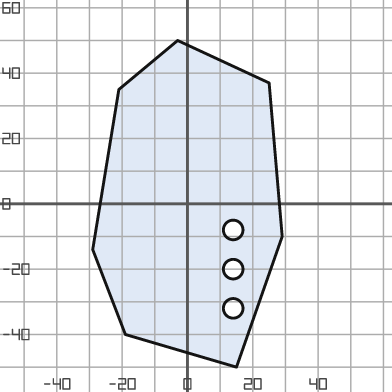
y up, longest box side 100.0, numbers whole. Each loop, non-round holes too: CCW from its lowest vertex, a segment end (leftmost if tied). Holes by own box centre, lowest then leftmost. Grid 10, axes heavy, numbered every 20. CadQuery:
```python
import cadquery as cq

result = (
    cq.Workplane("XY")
    .moveTo(15.0, -50.0)
    .lineTo(29.0, -10.0)
    .lineTo(25.0, 37.0)
    .lineTo(-3.0, 50.0)
    .lineTo(-21.0, 35.0)
    .lineTo(-29.0, -14.0)
    .lineTo(-19.0, -40.0)
    .close()
    .moveTo(14.0, -32.0)
    .circle(3.0)
    .moveTo(14.0, -20.0)
    .circle(3.0)
    .moveTo(14.0, -8.0)
    .circle(3.0)
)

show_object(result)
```